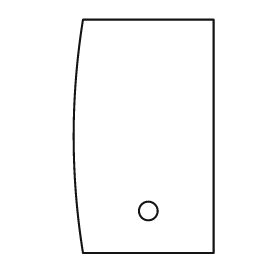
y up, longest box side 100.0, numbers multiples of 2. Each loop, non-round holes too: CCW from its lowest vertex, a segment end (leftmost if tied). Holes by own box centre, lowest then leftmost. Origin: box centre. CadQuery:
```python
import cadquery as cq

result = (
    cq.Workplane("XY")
    .moveTo(-26.0, -50.0)
    .lineTo(30.0, -50.0)
    .lineTo(30.0, 50.0)
    .lineTo(-26.0, 50.0)
    .threePointArc((-30.0, 0.0), (-26.0, -50.0))
    .close()
    .moveTo(2.0, -32.0)
    .circle(4.0)
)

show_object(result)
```